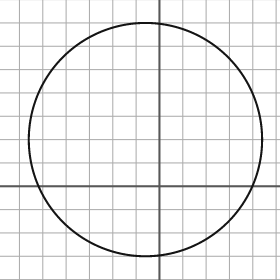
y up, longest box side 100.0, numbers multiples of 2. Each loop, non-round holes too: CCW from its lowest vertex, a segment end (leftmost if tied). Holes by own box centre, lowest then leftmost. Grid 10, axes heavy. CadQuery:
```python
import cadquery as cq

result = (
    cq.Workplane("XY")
    .moveTo(-6.0, 20.0)
    .circle(50.0)
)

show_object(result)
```